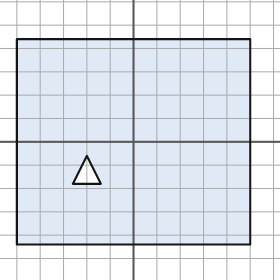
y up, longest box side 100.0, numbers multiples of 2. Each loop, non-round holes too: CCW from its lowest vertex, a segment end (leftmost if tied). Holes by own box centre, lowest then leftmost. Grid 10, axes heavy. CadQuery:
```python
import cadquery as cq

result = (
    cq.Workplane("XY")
    .moveTo(-50.0, -44.0)
    .lineTo(50.0, -44.0)
    .lineTo(50.0, 44.0)
    .lineTo(-50.0, 44.0)
    .close()
    .moveTo(-26.0, -18.0)
    .lineTo(-14.0, -18.0)
    .lineTo(-20.0, -6.0)
    .close()
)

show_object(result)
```